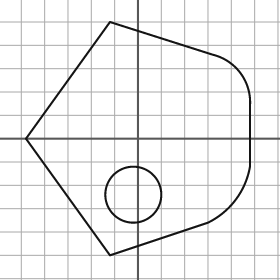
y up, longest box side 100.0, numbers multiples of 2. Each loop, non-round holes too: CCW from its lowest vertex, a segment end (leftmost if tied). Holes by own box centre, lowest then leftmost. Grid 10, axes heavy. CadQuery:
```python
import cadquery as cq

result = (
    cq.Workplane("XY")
    .moveTo(-12.0, -50.0)
    .lineTo(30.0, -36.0)
    .threePointArc((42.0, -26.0), (48.0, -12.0))
    .lineTo(48.0, 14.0)
    .threePointArc((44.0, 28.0), (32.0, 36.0))
    .lineTo(-12.0, 50.0)
    .lineTo(-48.0, 0.0)
    .close()
    .moveTo(-2.0, -24.0)
    .circle(12.0)
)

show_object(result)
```